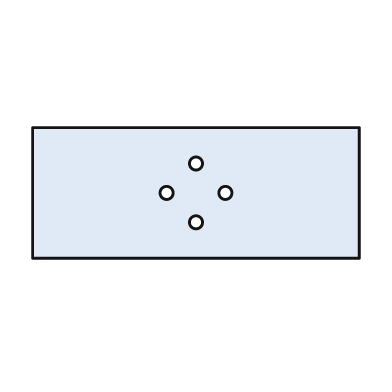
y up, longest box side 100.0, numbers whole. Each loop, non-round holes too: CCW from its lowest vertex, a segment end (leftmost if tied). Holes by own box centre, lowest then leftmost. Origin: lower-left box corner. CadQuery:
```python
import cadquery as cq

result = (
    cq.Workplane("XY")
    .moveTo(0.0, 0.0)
    .lineTo(100.0, 0.0)
    .lineTo(100.0, 40.0)
    .lineTo(0.0, 40.0)
    .close()
    .moveTo(50.0, 11.0)
    .circle(2.0)
    .moveTo(41.0, 20.0)
    .circle(2.0)
    .moveTo(59.0, 20.0)
    .circle(2.0)
    .moveTo(50.0, 29.0)
    .circle(2.0)
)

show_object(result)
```